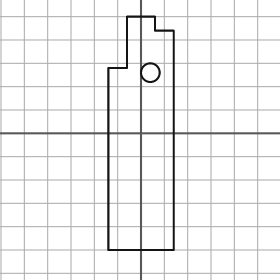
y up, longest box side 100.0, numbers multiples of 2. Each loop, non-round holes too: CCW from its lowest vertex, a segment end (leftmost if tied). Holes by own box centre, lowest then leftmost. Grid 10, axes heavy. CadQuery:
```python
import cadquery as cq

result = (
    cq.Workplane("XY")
    .moveTo(-14.0, -50.0)
    .lineTo(14.0, -50.0)
    .lineTo(14.0, 44.0)
    .lineTo(6.0, 44.0)
    .lineTo(6.0, 50.0)
    .lineTo(-6.0, 50.0)
    .lineTo(-6.0, 28.0)
    .lineTo(-14.0, 28.0)
    .close()
    .moveTo(4.0, 26.0)
    .circle(4.0)
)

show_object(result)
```